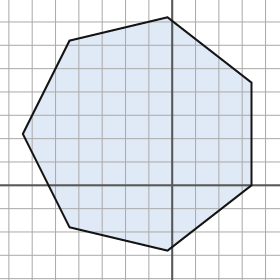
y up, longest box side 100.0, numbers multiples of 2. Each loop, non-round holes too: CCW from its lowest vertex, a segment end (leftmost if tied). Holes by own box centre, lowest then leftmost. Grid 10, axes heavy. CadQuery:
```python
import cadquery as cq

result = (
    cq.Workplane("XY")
    .moveTo(-2.0, -28.0)
    .lineTo(34.0, 0.0)
    .lineTo(34.0, 44.0)
    .lineTo(-2.0, 72.0)
    .lineTo(-44.0, 62.0)
    .lineTo(-64.0, 22.0)
    .lineTo(-44.0, -18.0)
    .close()
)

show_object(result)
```